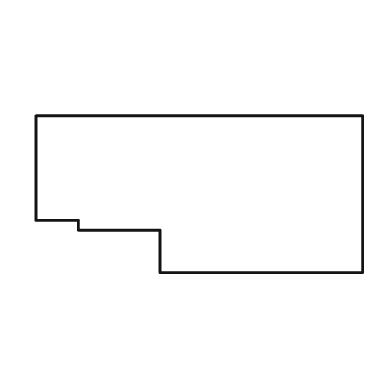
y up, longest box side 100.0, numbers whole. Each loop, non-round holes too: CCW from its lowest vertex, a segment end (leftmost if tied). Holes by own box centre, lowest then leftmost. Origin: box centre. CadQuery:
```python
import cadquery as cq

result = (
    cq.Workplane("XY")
    .moveTo(-12.0, -24.0)
    .lineTo(50.0, -24.0)
    .lineTo(50.0, 24.0)
    .lineTo(-50.0, 24.0)
    .lineTo(-50.0, -8.0)
    .lineTo(-37.0, -8.0)
    .lineTo(-37.0, -11.0)
    .lineTo(-12.0, -11.0)
    .close()
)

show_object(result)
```